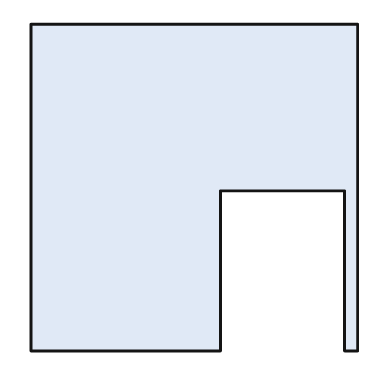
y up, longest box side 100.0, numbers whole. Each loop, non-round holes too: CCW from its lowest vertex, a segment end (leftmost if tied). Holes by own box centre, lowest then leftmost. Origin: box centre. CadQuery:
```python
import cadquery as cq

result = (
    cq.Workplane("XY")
    .moveTo(-50.0, -50.0)
    .lineTo(8.0, -50.0)
    .lineTo(8.0, -1.0)
    .lineTo(46.0, -1.0)
    .lineTo(46.0, -50.0)
    .lineTo(50.0, -50.0)
    .lineTo(50.0, 50.0)
    .lineTo(-50.0, 50.0)
    .close()
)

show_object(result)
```